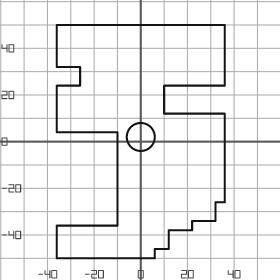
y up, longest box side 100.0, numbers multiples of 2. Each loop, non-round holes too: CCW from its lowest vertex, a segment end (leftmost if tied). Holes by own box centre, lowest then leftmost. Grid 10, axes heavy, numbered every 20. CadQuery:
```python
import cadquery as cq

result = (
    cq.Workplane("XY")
    .moveTo(-36.0, -50.0)
    .lineTo(6.0, -50.0)
    .lineTo(6.0, -46.0)
    .lineTo(12.0, -46.0)
    .lineTo(12.0, -38.0)
    .lineTo(22.0, -38.0)
    .lineTo(22.0, -34.0)
    .lineTo(32.0, -34.0)
    .lineTo(32.0, -26.0)
    .lineTo(36.0, -26.0)
    .lineTo(36.0, 12.0)
    .lineTo(10.0, 12.0)
    .lineTo(10.0, 24.0)
    .lineTo(36.0, 24.0)
    .lineTo(36.0, 50.0)
    .lineTo(-36.0, 50.0)
    .lineTo(-36.0, 32.0)
    .lineTo(-26.0, 32.0)
    .lineTo(-26.0, 24.0)
    .lineTo(-36.0, 24.0)
    .lineTo(-36.0, 4.0)
    .lineTo(-10.0, 4.0)
    .lineTo(-10.0, -36.0)
    .lineTo(-36.0, -36.0)
    .close()
    .moveTo(0.0, 2.0)
    .circle(6.0)
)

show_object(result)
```